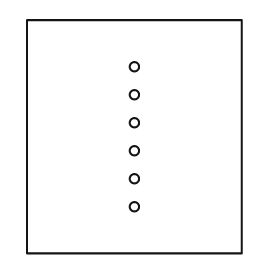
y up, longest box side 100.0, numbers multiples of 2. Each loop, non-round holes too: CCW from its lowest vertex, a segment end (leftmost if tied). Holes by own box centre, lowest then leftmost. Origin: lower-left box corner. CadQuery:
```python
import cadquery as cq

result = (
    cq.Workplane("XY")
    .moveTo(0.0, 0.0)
    .lineTo(92.0, 0.0)
    .lineTo(92.0, 100.0)
    .lineTo(0.0, 100.0)
    .close()
    .moveTo(46.0, 20.0)
    .circle(2.0)
    .moveTo(46.0, 32.0)
    .circle(2.0)
    .moveTo(46.0, 44.0)
    .circle(2.0)
    .moveTo(46.0, 56.0)
    .circle(2.0)
    .moveTo(46.0, 68.0)
    .circle(2.0)
    .moveTo(46.0, 80.0)
    .circle(2.0)
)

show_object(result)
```